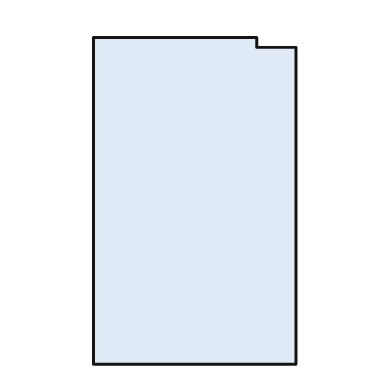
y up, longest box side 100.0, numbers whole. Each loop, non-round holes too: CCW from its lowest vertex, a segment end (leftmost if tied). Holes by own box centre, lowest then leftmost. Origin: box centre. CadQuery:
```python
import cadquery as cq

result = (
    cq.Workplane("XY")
    .moveTo(-31.0, -50.0)
    .lineTo(31.0, -50.0)
    .lineTo(31.0, 47.0)
    .lineTo(19.0, 47.0)
    .lineTo(19.0, 50.0)
    .lineTo(-31.0, 50.0)
    .close()
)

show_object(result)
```